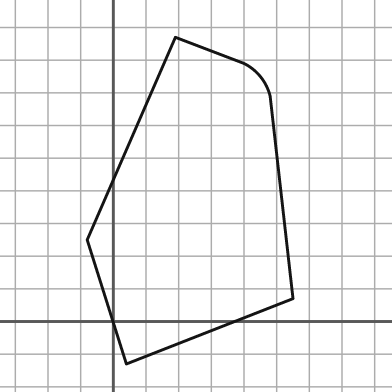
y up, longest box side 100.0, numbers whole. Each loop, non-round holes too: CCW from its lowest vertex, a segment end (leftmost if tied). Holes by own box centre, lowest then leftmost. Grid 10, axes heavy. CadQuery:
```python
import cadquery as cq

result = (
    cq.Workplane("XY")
    .moveTo(4.0, -13.0)
    .lineTo(55.0, 7.0)
    .lineTo(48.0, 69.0)
    .threePointArc((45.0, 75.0), (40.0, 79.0))
    .lineTo(19.0, 87.0)
    .lineTo(-8.0, 25.0)
    .close()
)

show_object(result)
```